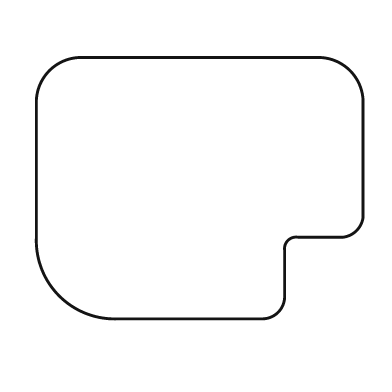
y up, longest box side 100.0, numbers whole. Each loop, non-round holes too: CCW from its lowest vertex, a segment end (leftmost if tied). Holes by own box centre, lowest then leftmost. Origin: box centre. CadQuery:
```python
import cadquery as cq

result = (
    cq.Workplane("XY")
    .moveTo(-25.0, -40.0)
    .lineTo(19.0, -40.0)
    .threePointArc((24.0, -38.0), (26.0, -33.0))
    .lineTo(26.0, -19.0)
    .threePointArc((27.0, -16.0), (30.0, -15.0))
    .lineTo(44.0, -15.0)
    .threePointArc((48.0, -13.0), (50.0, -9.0))
    .lineTo(50.0, 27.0)
    .threePointArc((46.0, 36.0), (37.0, 40.0))
    .lineTo(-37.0, 40.0)
    .threePointArc((-46.0, 36.0), (-50.0, 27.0))
    .lineTo(-50.0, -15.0)
    .threePointArc((-43.0, -33.0), (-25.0, -40.0))
    .close()
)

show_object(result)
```